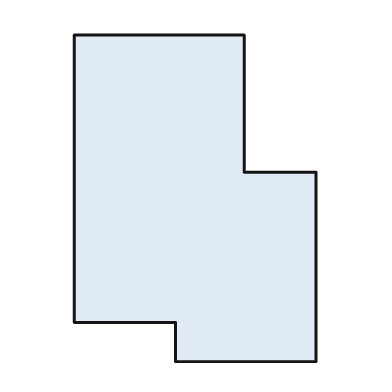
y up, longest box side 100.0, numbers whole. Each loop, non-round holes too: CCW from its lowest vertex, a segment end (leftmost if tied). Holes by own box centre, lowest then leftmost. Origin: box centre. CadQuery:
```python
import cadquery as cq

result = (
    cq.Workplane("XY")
    .moveTo(-6.0, -50.0)
    .lineTo(37.0, -50.0)
    .lineTo(37.0, 8.0)
    .lineTo(15.0, 8.0)
    .lineTo(15.0, 50.0)
    .lineTo(-37.0, 50.0)
    .lineTo(-37.0, -38.0)
    .lineTo(-6.0, -38.0)
    .close()
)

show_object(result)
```